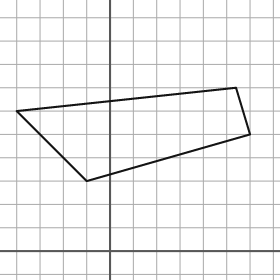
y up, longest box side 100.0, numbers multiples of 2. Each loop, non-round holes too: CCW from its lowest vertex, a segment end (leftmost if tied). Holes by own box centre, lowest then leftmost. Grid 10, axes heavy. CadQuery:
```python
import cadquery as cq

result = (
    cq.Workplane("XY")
    .moveTo(-10.0, 30.0)
    .lineTo(60.0, 50.0)
    .lineTo(54.0, 70.0)
    .lineTo(-40.0, 60.0)
    .close()
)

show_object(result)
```